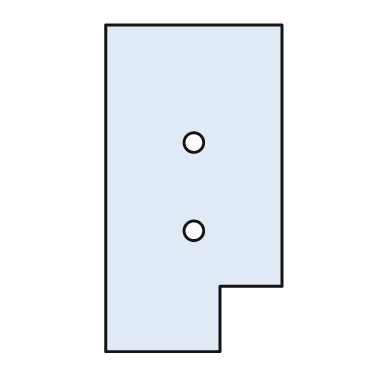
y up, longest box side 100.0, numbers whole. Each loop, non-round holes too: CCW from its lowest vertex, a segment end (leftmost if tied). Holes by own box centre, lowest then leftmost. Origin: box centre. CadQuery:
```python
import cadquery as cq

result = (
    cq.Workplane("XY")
    .moveTo(-27.0, -50.0)
    .lineTo(8.0, -50.0)
    .lineTo(8.0, -30.0)
    .lineTo(27.0, -30.0)
    .lineTo(27.0, 50.0)
    .lineTo(-27.0, 50.0)
    .close()
    .moveTo(0.0, -13.0)
    .circle(3.0)
    .moveTo(0.0, 14.0)
    .circle(3.0)
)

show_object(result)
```